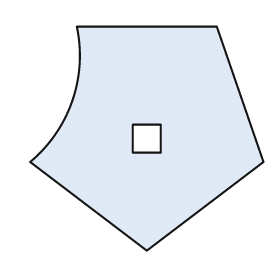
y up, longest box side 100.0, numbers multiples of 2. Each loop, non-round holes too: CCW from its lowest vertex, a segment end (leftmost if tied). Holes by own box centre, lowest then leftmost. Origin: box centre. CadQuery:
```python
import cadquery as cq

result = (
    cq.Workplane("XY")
    .moveTo(0.0, -48.0)
    .lineTo(50.0, -10.0)
    .lineTo(30.0, 48.0)
    .lineTo(-30.0, 48.0)
    .threePointArc((-32.0, 16.0), (-50.0, -10.0))
    .close()
    .moveTo(-6.0, -6.0)
    .lineTo(6.0, -6.0)
    .lineTo(6.0, 6.0)
    .lineTo(-6.0, 6.0)
    .close()
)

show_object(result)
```